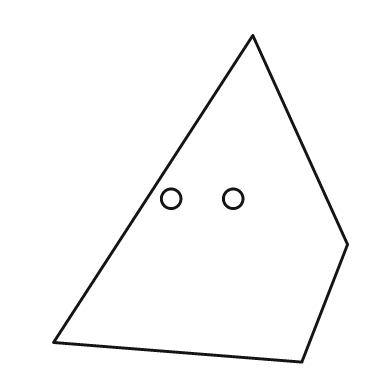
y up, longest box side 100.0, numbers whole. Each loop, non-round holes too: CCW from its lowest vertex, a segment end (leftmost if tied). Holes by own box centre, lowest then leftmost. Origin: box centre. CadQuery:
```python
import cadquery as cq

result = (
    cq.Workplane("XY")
    .moveTo(31.0, -50.0)
    .lineTo(45.0, -14.0)
    .lineTo(16.0, 50.0)
    .lineTo(-45.0, -44.0)
    .close()
    .moveTo(-9.0, 0.0)
    .circle(3.0)
    .moveTo(10.0, 0.0)
    .circle(3.0)
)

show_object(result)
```